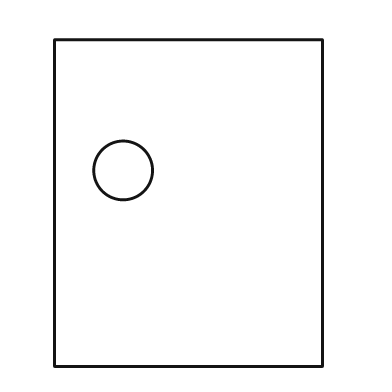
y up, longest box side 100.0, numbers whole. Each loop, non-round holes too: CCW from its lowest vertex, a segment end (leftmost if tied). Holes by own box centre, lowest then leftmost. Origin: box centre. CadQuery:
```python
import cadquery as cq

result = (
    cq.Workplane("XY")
    .moveTo(-41.0, -50.0)
    .lineTo(41.0, -50.0)
    .lineTo(41.0, 50.0)
    .lineTo(-41.0, 50.0)
    .close()
    .moveTo(-20.0, 10.0)
    .circle(9.0)
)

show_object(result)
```